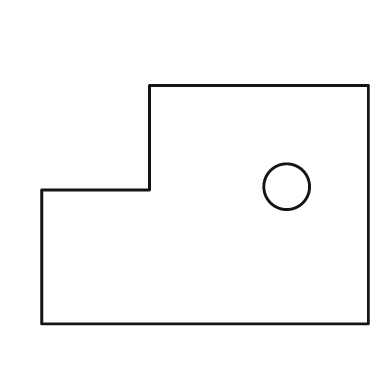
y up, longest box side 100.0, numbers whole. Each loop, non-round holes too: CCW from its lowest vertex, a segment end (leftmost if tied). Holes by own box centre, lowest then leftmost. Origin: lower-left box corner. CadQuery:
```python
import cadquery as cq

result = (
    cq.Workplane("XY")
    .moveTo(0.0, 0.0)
    .lineTo(100.0, 0.0)
    .lineTo(100.0, 73.0)
    .lineTo(33.0, 73.0)
    .lineTo(33.0, 41.0)
    .lineTo(0.0, 41.0)
    .close()
    .moveTo(75.0, 42.0)
    .circle(7.0)
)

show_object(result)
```